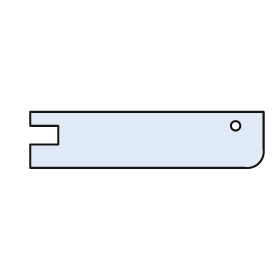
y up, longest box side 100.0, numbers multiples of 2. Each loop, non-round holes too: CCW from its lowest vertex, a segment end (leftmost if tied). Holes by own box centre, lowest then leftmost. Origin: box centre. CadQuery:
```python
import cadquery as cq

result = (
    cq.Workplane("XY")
    .moveTo(-50.0, -12.0)
    .lineTo(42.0, -12.0)
    .threePointArc((48.0, -10.0), (50.0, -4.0))
    .lineTo(50.0, 12.0)
    .lineTo(-50.0, 12.0)
    .lineTo(-50.0, 6.0)
    .lineTo(-38.0, 6.0)
    .lineTo(-38.0, -2.0)
    .lineTo(-50.0, -2.0)
    .close()
    .moveTo(38.0, 6.0)
    .circle(2.0)
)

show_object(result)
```